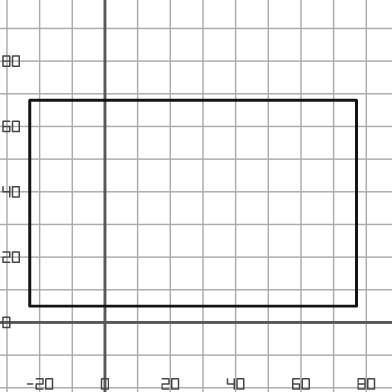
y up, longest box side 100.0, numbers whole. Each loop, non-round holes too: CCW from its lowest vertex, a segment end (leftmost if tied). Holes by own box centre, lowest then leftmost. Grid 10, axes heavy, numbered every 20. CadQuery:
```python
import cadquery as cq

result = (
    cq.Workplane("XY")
    .moveTo(-23.0, 5.0)
    .lineTo(77.0, 5.0)
    .lineTo(77.0, 68.0)
    .lineTo(-23.0, 68.0)
    .close()
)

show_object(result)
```